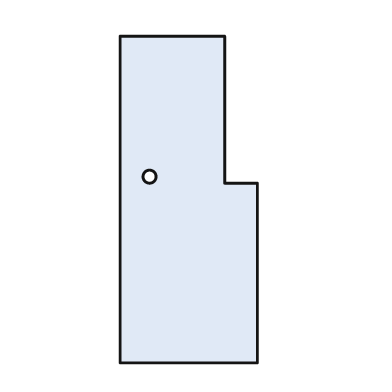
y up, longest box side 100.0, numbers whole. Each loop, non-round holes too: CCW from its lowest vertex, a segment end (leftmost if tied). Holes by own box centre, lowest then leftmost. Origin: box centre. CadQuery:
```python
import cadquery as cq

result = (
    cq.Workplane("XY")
    .moveTo(-21.0, -50.0)
    .lineTo(21.0, -50.0)
    .lineTo(21.0, 5.0)
    .lineTo(11.0, 5.0)
    .lineTo(11.0, 50.0)
    .lineTo(-21.0, 50.0)
    .close()
    .moveTo(-12.0, 7.0)
    .circle(2.0)
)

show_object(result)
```